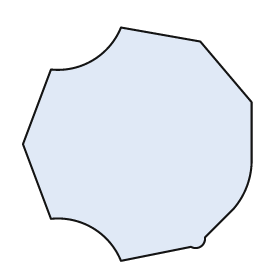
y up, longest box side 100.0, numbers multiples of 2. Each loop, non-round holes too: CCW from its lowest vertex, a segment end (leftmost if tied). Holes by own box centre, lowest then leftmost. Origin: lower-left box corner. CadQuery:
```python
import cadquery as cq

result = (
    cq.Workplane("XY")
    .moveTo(42.0, 0.0)
    .lineTo(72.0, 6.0)
    .threePointArc((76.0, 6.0), (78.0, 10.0))
    .lineTo(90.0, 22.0)
    .threePointArc((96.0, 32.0), (98.0, 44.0))
    .lineTo(98.0, 68.0)
    .lineTo(76.0, 94.0)
    .lineTo(42.0, 100.0)
    .threePointArc((30.0, 86.0), (12.0, 82.0))
    .lineTo(0.0, 50.0)
    .lineTo(12.0, 18.0)
    .threePointArc((30.0, 14.0), (42.0, 0.0))
    .close()
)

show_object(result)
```